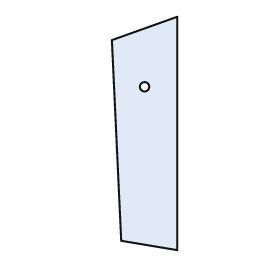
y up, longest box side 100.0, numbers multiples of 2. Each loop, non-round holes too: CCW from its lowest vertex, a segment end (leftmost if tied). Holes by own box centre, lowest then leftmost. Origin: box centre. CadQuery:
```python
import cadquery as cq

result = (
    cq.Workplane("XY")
    .moveTo(14.0, -50.0)
    .lineTo(14.0, 50.0)
    .lineTo(-14.0, 40.0)
    .lineTo(-10.0, -46.0)
    .close()
    .moveTo(0.0, 20.0)
    .circle(2.0)
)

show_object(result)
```